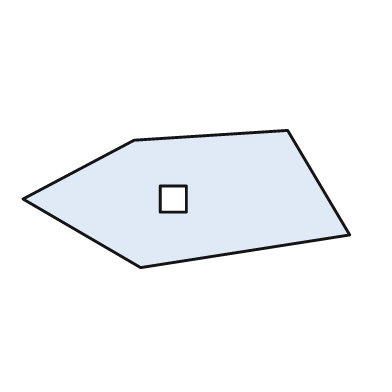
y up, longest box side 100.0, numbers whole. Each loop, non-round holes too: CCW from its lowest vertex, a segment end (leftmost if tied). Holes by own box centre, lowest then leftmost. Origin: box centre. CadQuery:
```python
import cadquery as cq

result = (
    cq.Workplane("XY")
    .moveTo(-14.0, -21.0)
    .lineTo(50.0, -11.0)
    .lineTo(31.0, 21.0)
    .lineTo(-16.0, 18.0)
    .lineTo(-50.0, 0.0)
    .close()
    .moveTo(-8.0, -4.0)
    .lineTo(0.0, -4.0)
    .lineTo(0.0, 4.0)
    .lineTo(-8.0, 4.0)
    .close()
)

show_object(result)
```